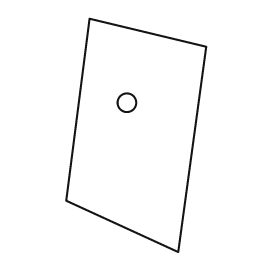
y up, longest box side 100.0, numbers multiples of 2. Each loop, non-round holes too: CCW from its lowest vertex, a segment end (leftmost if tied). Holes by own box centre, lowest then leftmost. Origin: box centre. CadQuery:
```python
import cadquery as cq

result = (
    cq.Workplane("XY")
    .moveTo(18.0, -50.0)
    .lineTo(30.0, 38.0)
    .lineTo(-20.0, 50.0)
    .lineTo(-30.0, -28.0)
    .close()
    .moveTo(-4.0, 14.0)
    .circle(4.0)
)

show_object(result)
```